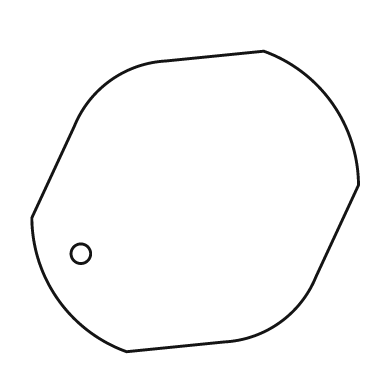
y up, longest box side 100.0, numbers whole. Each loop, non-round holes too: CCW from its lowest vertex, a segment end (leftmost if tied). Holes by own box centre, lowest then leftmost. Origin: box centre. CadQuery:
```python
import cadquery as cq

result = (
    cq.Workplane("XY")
    .moveTo(-21.0, -46.0)
    .lineTo(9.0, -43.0)
    .threePointArc((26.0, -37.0), (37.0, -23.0))
    .lineTo(50.0, 5.0)
    .threePointArc((42.0, 30.0), (21.0, 46.0))
    .lineTo(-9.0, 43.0)
    .threePointArc((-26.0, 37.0), (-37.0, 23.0))
    .lineTo(-50.0, -5.0)
    .threePointArc((-42.0, -30.0), (-21.0, -46.0))
    .close()
    .moveTo(-35.0, -16.0)
    .circle(3.0)
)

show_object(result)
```